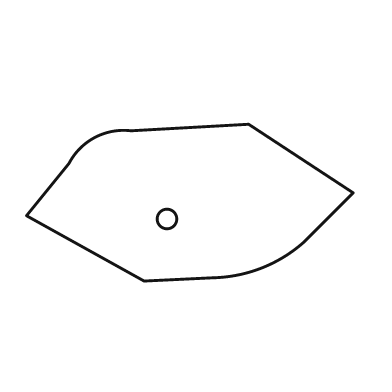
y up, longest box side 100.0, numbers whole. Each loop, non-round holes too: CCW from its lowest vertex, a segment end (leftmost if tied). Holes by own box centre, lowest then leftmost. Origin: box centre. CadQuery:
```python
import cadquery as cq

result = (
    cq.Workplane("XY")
    .moveTo(-14.0, -24.0)
    .lineTo(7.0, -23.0)
    .threePointArc((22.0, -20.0), (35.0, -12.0))
    .lineTo(50.0, 3.0)
    .lineTo(18.0, 24.0)
    .lineTo(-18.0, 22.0)
    .threePointArc((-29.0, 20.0), (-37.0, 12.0))
    .lineTo(-50.0, -4.0)
    .close()
    .moveTo(-7.0, -5.0)
    .circle(3.0)
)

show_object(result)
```